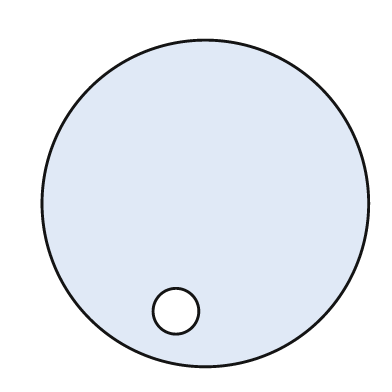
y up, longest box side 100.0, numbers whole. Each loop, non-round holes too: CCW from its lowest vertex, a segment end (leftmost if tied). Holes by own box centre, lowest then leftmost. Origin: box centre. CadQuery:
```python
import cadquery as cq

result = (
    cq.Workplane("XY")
    .moveTo(0.0, 0.0)
    .circle(50.0)
    .moveTo(-9.0, -33.0)
    .circle(7.0)
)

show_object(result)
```